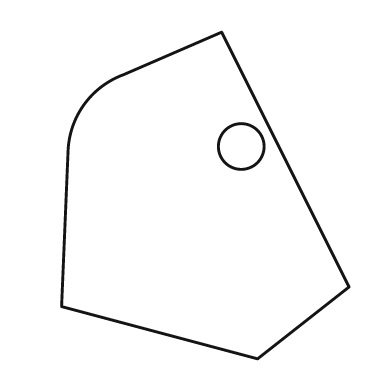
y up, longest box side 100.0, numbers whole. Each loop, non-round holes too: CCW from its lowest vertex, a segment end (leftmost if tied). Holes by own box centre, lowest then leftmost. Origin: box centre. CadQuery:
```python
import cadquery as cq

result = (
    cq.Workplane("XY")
    .moveTo(16.0, -50.0)
    .lineTo(44.0, -28.0)
    .lineTo(5.0, 50.0)
    .lineTo(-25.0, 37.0)
    .threePointArc((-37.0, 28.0), (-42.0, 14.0))
    .lineTo(-44.0, -34.0)
    .close()
    .moveTo(11.0, 15.0)
    .circle(7.0)
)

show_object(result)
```